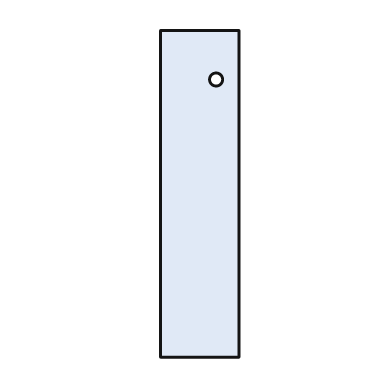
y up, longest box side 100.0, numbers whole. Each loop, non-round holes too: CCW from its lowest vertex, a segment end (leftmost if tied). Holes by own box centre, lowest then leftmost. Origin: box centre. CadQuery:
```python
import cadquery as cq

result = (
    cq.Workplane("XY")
    .moveTo(-12.0, -50.0)
    .lineTo(12.0, -50.0)
    .lineTo(12.0, 50.0)
    .lineTo(-12.0, 50.0)
    .close()
    .moveTo(5.0, 35.0)
    .circle(2.0)
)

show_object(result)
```